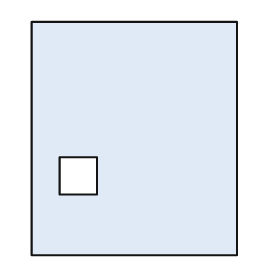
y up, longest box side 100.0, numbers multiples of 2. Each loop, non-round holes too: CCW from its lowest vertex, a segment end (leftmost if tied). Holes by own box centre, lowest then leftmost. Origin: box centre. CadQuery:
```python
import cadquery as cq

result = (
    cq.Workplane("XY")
    .moveTo(-44.0, -50.0)
    .lineTo(44.0, -50.0)
    .lineTo(44.0, 50.0)
    .lineTo(-44.0, 50.0)
    .close()
    .moveTo(-32.0, -24.0)
    .lineTo(-16.0, -24.0)
    .lineTo(-16.0, -8.0)
    .lineTo(-32.0, -8.0)
    .close()
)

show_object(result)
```